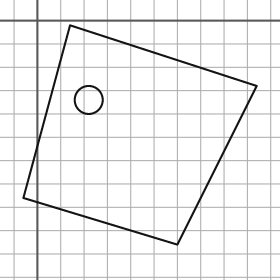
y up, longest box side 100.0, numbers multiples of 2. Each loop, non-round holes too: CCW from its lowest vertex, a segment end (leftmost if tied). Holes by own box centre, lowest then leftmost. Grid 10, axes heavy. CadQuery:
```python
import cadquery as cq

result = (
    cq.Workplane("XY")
    .moveTo(60.0, -96.0)
    .lineTo(94.0, -28.0)
    .lineTo(14.0, -2.0)
    .lineTo(-6.0, -76.0)
    .close()
    .moveTo(22.0, -34.0)
    .circle(6.0)
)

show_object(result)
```